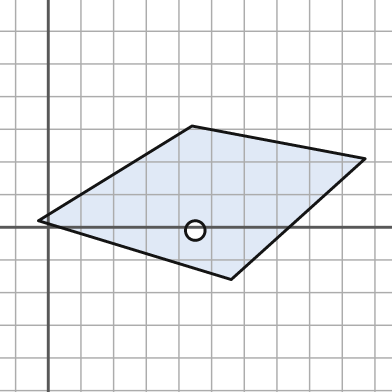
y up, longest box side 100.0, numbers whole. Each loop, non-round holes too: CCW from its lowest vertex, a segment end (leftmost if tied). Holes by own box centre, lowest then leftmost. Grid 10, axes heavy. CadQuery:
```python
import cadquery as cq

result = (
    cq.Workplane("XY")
    .moveTo(56.0, -16.0)
    .lineTo(97.0, 21.0)
    .lineTo(44.0, 31.0)
    .lineTo(-3.0, 2.0)
    .close()
    .moveTo(45.0, -1.0)
    .circle(3.0)
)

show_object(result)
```